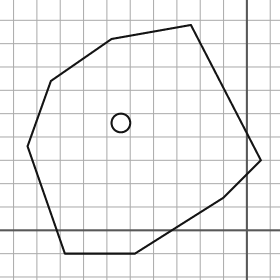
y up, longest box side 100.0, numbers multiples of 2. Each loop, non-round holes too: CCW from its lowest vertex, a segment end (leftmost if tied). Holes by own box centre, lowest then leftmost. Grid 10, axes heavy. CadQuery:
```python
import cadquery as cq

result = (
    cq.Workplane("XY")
    .moveTo(-78.0, -10.0)
    .lineTo(-48.0, -10.0)
    .lineTo(-10.0, 14.0)
    .lineTo(6.0, 30.0)
    .lineTo(-24.0, 88.0)
    .lineTo(-58.0, 82.0)
    .lineTo(-84.0, 64.0)
    .lineTo(-94.0, 36.0)
    .close()
    .moveTo(-54.0, 46.0)
    .circle(4.0)
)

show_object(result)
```